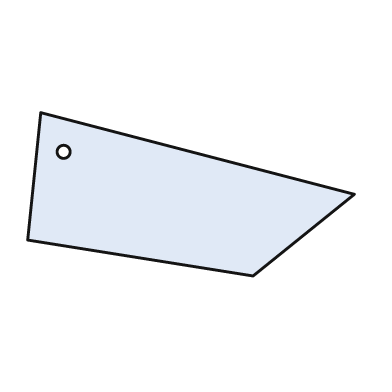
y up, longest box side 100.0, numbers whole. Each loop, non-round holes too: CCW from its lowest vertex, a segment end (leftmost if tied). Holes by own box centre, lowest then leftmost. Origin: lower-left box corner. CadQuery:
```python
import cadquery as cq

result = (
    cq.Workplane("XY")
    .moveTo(69.0, 0.0)
    .lineTo(100.0, 25.0)
    .lineTo(4.0, 50.0)
    .lineTo(0.0, 11.0)
    .close()
    .moveTo(11.0, 38.0)
    .circle(2.0)
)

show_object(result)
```